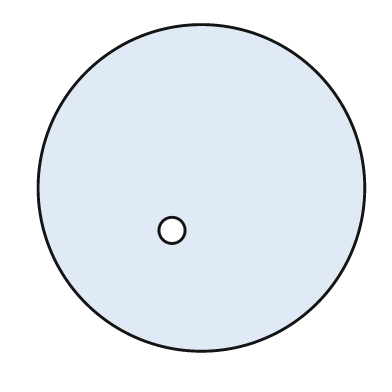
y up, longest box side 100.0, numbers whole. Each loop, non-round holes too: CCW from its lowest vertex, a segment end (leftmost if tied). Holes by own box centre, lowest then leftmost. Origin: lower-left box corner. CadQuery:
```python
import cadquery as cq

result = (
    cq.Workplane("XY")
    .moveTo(50.0, 50.0)
    .circle(50.0)
    .moveTo(41.0, 37.0)
    .circle(4.0)
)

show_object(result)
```